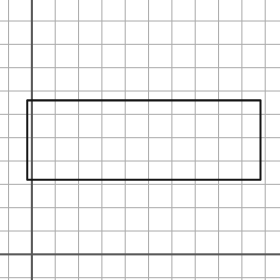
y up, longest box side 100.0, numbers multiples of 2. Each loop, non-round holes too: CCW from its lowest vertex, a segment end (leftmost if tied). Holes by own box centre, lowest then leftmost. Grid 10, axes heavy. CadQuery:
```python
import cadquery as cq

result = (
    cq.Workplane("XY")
    .moveTo(-2.0, 32.0)
    .lineTo(98.0, 32.0)
    .lineTo(98.0, 66.0)
    .lineTo(-2.0, 66.0)
    .close()
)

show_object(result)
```